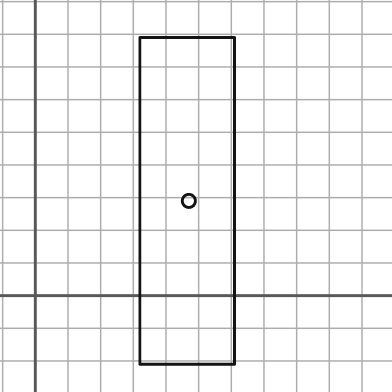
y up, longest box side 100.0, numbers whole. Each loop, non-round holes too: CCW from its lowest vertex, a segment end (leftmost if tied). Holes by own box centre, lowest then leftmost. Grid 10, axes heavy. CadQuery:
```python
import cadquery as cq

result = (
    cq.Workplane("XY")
    .moveTo(32.0, -21.0)
    .lineTo(61.0, -21.0)
    .lineTo(61.0, 79.0)
    .lineTo(32.0, 79.0)
    .close()
    .moveTo(47.0, 29.0)
    .circle(2.0)
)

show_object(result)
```